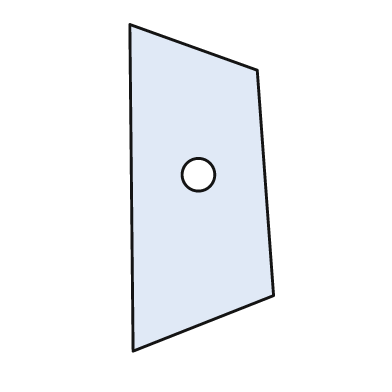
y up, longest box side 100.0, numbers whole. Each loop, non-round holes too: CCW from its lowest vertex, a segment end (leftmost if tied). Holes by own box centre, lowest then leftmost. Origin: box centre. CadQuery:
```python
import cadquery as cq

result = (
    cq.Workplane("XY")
    .moveTo(-21.0, -50.0)
    .lineTo(22.0, -33.0)
    .lineTo(17.0, 36.0)
    .lineTo(-22.0, 50.0)
    .close()
    .moveTo(-1.0, 4.0)
    .circle(5.0)
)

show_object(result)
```